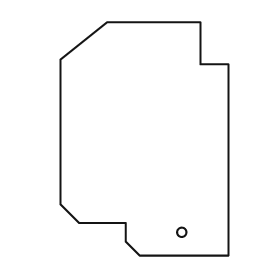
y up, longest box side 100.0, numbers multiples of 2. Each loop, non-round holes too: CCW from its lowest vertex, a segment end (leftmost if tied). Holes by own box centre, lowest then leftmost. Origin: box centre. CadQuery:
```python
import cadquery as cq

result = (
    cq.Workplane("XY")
    .moveTo(-2.0, -50.0)
    .lineTo(36.0, -50.0)
    .lineTo(36.0, 32.0)
    .lineTo(24.0, 32.0)
    .lineTo(24.0, 50.0)
    .lineTo(-16.0, 50.0)
    .lineTo(-36.0, 34.0)
    .lineTo(-36.0, -28.0)
    .lineTo(-28.0, -36.0)
    .lineTo(-8.0, -36.0)
    .lineTo(-8.0, -44.0)
    .close()
    .moveTo(16.0, -40.0)
    .circle(2.0)
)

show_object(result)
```